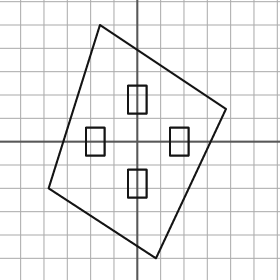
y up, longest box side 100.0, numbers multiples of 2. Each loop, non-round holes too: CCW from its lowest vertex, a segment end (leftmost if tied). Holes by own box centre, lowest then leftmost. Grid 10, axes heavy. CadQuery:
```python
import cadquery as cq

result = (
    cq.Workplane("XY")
    .moveTo(8.0, -50.0)
    .lineTo(38.0, 14.0)
    .lineTo(-16.0, 50.0)
    .lineTo(-38.0, -20.0)
    .close()
    .moveTo(-4.0, -24.0)
    .lineTo(4.0, -24.0)
    .lineTo(4.0, -12.0)
    .lineTo(-4.0, -12.0)
    .close()
    .moveTo(-22.0, -6.0)
    .lineTo(-14.0, -6.0)
    .lineTo(-14.0, 6.0)
    .lineTo(-22.0, 6.0)
    .close()
    .moveTo(14.0, -6.0)
    .lineTo(22.0, -6.0)
    .lineTo(22.0, 6.0)
    .lineTo(14.0, 6.0)
    .close()
    .moveTo(-4.0, 12.0)
    .lineTo(4.0, 12.0)
    .lineTo(4.0, 24.0)
    .lineTo(-4.0, 24.0)
    .close()
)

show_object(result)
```